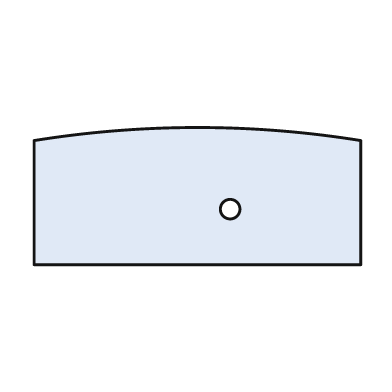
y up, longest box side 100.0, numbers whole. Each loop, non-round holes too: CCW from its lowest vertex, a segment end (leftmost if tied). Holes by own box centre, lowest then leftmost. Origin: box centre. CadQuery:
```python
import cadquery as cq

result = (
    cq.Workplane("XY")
    .moveTo(-50.0, -21.0)
    .lineTo(50.0, -21.0)
    .lineTo(50.0, 17.0)
    .threePointArc((0.0, 21.0), (-50.0, 17.0))
    .close()
    .moveTo(10.0, -4.0)
    .circle(3.0)
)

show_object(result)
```